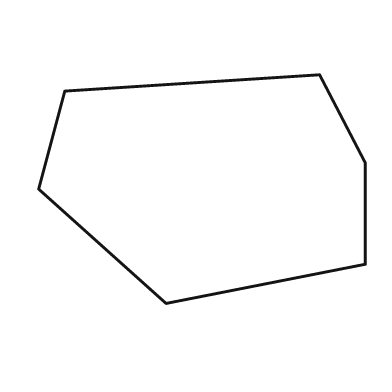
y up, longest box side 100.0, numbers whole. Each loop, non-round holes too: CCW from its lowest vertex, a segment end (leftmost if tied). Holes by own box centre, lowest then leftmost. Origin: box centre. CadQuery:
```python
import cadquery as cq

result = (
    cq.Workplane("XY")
    .moveTo(-11.0, -35.0)
    .lineTo(50.0, -23.0)
    .lineTo(50.0, 8.0)
    .lineTo(36.0, 35.0)
    .lineTo(-42.0, 30.0)
    .lineTo(-50.0, 0.0)
    .close()
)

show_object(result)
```